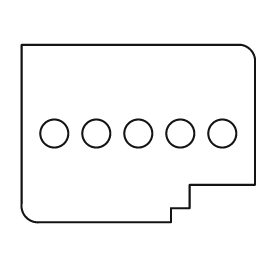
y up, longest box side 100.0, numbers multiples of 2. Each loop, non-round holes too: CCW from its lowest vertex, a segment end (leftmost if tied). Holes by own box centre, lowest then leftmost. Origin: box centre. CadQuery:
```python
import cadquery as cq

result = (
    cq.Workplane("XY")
    .moveTo(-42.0, -38.0)
    .lineTo(14.0, -38.0)
    .lineTo(14.0, -32.0)
    .lineTo(22.0, -32.0)
    .lineTo(22.0, -22.0)
    .lineTo(50.0, -22.0)
    .lineTo(50.0, 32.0)
    .threePointArc((48.0, 36.0), (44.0, 38.0))
    .lineTo(-50.0, 38.0)
    .lineTo(-50.0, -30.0)
    .threePointArc((-48.0, -36.0), (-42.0, -38.0))
    .close()
    .moveTo(-36.0, 0.0)
    .circle(6.0)
    .moveTo(-18.0, 0.0)
    .circle(6.0)
    .moveTo(0.0, 0.0)
    .circle(6.0)
    .moveTo(18.0, 0.0)
    .circle(6.0)
    .moveTo(36.0, 0.0)
    .circle(6.0)
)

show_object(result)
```